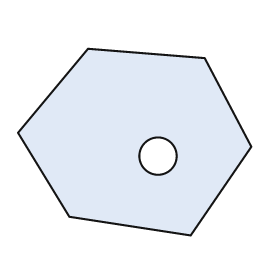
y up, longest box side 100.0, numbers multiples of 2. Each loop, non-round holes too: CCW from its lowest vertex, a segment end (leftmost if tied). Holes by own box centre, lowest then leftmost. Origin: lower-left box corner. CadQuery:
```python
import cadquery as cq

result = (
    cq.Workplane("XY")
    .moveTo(74.0, 0.0)
    .lineTo(100.0, 38.0)
    .lineTo(80.0, 76.0)
    .lineTo(30.0, 80.0)
    .lineTo(0.0, 44.0)
    .lineTo(22.0, 8.0)
    .close()
    .moveTo(60.0, 34.0)
    .circle(8.0)
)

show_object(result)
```